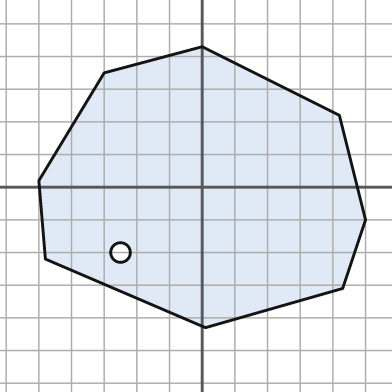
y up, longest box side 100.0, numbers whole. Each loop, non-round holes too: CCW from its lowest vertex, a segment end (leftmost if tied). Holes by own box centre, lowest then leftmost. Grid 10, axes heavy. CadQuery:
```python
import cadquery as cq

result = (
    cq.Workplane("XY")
    .moveTo(1.0, -43.0)
    .lineTo(43.0, -31.0)
    .lineTo(50.0, -10.0)
    .lineTo(42.0, 22.0)
    .lineTo(0.0, 43.0)
    .lineTo(-30.0, 35.0)
    .lineTo(-50.0, 2.0)
    .lineTo(-48.0, -22.0)
    .close()
    .moveTo(-25.0, -20.0)
    .circle(3.0)
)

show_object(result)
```